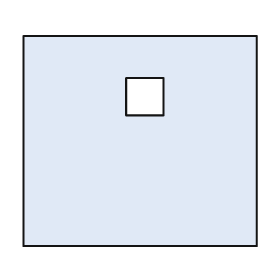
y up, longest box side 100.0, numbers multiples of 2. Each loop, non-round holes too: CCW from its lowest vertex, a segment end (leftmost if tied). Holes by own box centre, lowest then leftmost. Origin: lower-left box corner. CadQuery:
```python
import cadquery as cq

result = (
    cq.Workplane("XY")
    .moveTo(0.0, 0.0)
    .lineTo(100.0, 0.0)
    .lineTo(100.0, 90.0)
    .lineTo(0.0, 90.0)
    .close()
    .moveTo(44.0, 56.0)
    .lineTo(60.0, 56.0)
    .lineTo(60.0, 72.0)
    .lineTo(44.0, 72.0)
    .close()
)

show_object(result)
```